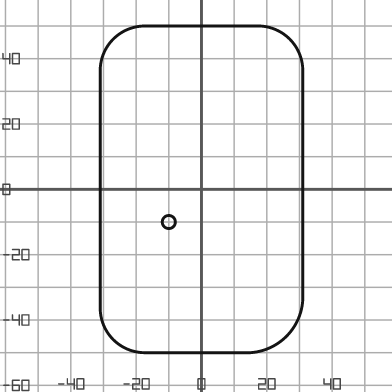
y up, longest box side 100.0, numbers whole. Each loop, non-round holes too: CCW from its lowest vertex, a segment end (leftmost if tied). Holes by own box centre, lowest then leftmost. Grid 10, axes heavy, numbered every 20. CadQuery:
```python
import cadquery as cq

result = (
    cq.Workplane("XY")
    .moveTo(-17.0, -50.0)
    .lineTo(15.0, -50.0)
    .threePointArc((26.0, -45.0), (31.0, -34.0))
    .lineTo(31.0, 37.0)
    .threePointArc((27.0, 46.0), (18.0, 50.0))
    .lineTo(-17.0, 50.0)
    .threePointArc((-27.0, 46.0), (-31.0, 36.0))
    .lineTo(-31.0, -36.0)
    .threePointArc((-27.0, -46.0), (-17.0, -50.0))
    .close()
    .moveTo(-10.0, -10.0)
    .circle(2.0)
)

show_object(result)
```